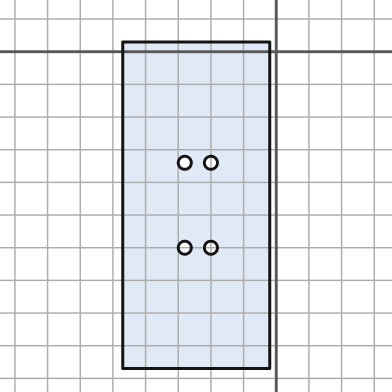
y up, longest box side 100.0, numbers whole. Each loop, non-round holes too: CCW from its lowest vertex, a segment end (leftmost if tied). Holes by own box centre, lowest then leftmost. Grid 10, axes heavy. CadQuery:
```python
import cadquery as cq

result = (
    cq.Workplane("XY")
    .moveTo(-47.0, -97.0)
    .lineTo(-2.0, -97.0)
    .lineTo(-2.0, 3.0)
    .lineTo(-47.0, 3.0)
    .close()
    .moveTo(-28.0, -60.0)
    .circle(2.0)
    .moveTo(-20.0, -60.0)
    .circle(2.0)
    .moveTo(-28.0, -34.0)
    .circle(2.0)
    .moveTo(-20.0, -34.0)
    .circle(2.0)
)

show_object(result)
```